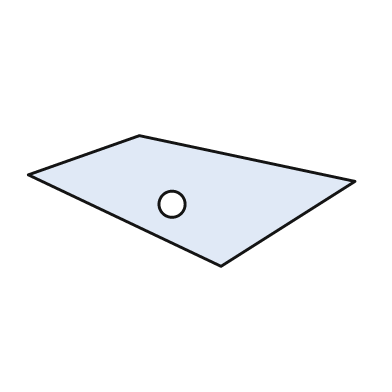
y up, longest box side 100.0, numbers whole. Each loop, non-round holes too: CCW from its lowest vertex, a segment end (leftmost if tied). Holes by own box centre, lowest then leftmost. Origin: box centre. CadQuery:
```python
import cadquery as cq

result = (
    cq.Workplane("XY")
    .moveTo(9.0, -20.0)
    .lineTo(50.0, 6.0)
    .lineTo(-16.0, 20.0)
    .lineTo(-50.0, 8.0)
    .close()
    .moveTo(-6.0, -1.0)
    .circle(4.0)
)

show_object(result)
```